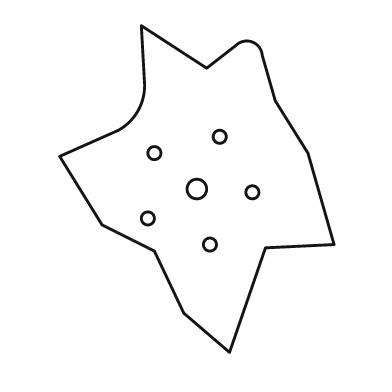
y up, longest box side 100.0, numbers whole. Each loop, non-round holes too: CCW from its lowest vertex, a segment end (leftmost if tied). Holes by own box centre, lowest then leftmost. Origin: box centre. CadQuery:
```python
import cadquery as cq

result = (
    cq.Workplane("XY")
    .moveTo(10.0, -50.0)
    .lineTo(21.0, -18.0)
    .lineTo(42.0, -17.0)
    .lineTo(34.0, 11.0)
    .lineTo(24.0, 27.0)
    .lineTo(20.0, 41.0)
    .threePointArc((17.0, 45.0), (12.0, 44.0))
    .lineTo(3.0, 37.0)
    .lineTo(-17.0, 50.0)
    .lineTo(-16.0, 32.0)
    .threePointArc((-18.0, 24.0), (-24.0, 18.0))
    .lineTo(-42.0, 10.0)
    .lineTo(-29.0, -11.0)
    .lineTo(-13.0, -19.0)
    .lineTo(-4.0, -38.0)
    .close()
    .moveTo(4.0, -17.0)
    .circle(2.0)
    .moveTo(-15.0, -9.0)
    .circle(2.0)
    .moveTo(17.0, -1.0)
    .circle(2.0)
    .moveTo(0.0, 0.0)
    .circle(3.0)
    .moveTo(-13.0, 11.0)
    .circle(2.0)
    .moveTo(7.0, 16.0)
    .circle(2.0)
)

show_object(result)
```